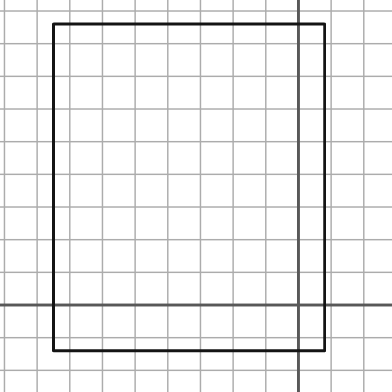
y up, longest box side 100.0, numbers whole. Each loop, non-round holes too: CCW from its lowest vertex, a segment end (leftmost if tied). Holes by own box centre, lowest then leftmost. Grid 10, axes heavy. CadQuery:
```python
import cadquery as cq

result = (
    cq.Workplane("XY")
    .moveTo(-75.0, -14.0)
    .lineTo(8.0, -14.0)
    .lineTo(8.0, 86.0)
    .lineTo(-75.0, 86.0)
    .close()
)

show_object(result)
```